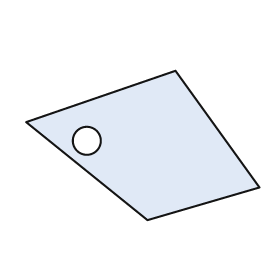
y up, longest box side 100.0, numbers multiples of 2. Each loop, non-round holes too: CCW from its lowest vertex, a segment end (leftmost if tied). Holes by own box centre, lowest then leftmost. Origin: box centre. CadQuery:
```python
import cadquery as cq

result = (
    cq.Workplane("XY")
    .moveTo(2.0, -32.0)
    .lineTo(50.0, -18.0)
    .lineTo(14.0, 32.0)
    .lineTo(-50.0, 10.0)
    .close()
    .moveTo(-24.0, 2.0)
    .circle(6.0)
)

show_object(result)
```